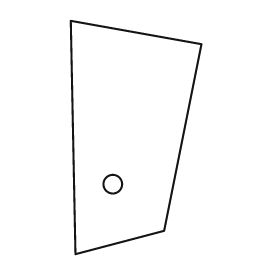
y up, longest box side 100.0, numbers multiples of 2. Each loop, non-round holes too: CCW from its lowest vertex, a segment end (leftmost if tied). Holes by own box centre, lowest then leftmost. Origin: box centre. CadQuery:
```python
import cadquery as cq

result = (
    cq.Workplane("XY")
    .moveTo(-26.0, -50.0)
    .lineTo(12.0, -40.0)
    .lineTo(28.0, 40.0)
    .lineTo(-28.0, 50.0)
    .close()
    .moveTo(-10.0, -20.0)
    .circle(4.0)
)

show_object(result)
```